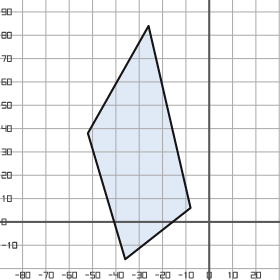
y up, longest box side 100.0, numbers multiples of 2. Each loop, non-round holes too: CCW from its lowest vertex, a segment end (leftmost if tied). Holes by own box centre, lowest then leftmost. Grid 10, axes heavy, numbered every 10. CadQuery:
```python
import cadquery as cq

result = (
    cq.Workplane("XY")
    .moveTo(-36.0, -16.0)
    .lineTo(-8.0, 6.0)
    .lineTo(-26.0, 84.0)
    .lineTo(-52.0, 38.0)
    .close()
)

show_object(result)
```